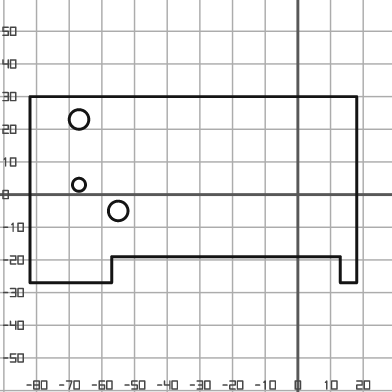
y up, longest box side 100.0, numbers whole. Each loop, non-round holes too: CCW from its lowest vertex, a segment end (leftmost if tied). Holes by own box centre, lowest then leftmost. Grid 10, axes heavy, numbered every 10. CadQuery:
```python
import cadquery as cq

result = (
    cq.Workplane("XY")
    .moveTo(-82.0, -27.0)
    .lineTo(-57.0, -27.0)
    .lineTo(-57.0, -19.0)
    .lineTo(13.0, -19.0)
    .lineTo(13.0, -27.0)
    .lineTo(18.0, -27.0)
    .lineTo(18.0, 30.0)
    .lineTo(-82.0, 30.0)
    .close()
    .moveTo(-55.0, -5.0)
    .circle(3.0)
    .moveTo(-67.0, 3.0)
    .circle(2.0)
    .moveTo(-67.0, 23.0)
    .circle(3.0)
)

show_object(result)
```